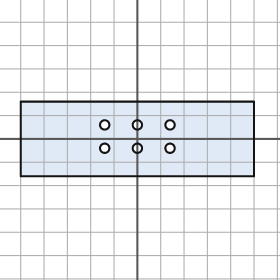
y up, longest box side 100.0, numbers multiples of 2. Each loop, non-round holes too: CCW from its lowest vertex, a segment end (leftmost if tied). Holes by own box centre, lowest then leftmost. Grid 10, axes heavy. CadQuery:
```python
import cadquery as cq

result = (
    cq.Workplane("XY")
    .moveTo(-50.0, -16.0)
    .lineTo(50.0, -16.0)
    .lineTo(50.0, 16.0)
    .lineTo(-50.0, 16.0)
    .close()
    .moveTo(-14.0, -4.0)
    .circle(2.0)
    .moveTo(0.0, -4.0)
    .circle(2.0)
    .moveTo(14.0, -4.0)
    .circle(2.0)
    .moveTo(-14.0, 6.0)
    .circle(2.0)
    .moveTo(0.0, 6.0)
    .circle(2.0)
    .moveTo(14.0, 6.0)
    .circle(2.0)
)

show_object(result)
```